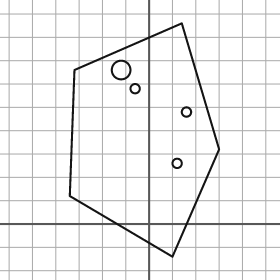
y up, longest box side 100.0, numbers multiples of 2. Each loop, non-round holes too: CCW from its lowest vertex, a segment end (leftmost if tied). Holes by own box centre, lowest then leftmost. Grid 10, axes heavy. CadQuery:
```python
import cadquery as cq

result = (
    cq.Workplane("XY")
    .moveTo(10.0, -14.0)
    .lineTo(30.0, 32.0)
    .lineTo(14.0, 86.0)
    .lineTo(-32.0, 66.0)
    .lineTo(-34.0, 12.0)
    .close()
    .moveTo(12.0, 26.0)
    .circle(2.0)
    .moveTo(16.0, 48.0)
    .circle(2.0)
    .moveTo(-6.0, 58.0)
    .circle(2.0)
    .moveTo(-12.0, 66.0)
    .circle(4.0)
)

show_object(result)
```